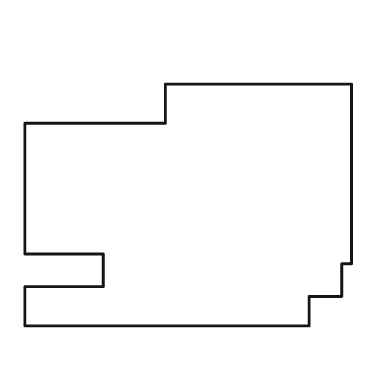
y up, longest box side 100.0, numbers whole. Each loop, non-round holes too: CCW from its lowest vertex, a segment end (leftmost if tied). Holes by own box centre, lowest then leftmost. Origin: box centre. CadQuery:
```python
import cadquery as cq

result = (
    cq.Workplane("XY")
    .moveTo(-50.0, -37.0)
    .lineTo(37.0, -37.0)
    .lineTo(37.0, -28.0)
    .lineTo(47.0, -28.0)
    .lineTo(47.0, -18.0)
    .lineTo(50.0, -18.0)
    .lineTo(50.0, 37.0)
    .lineTo(-7.0, 37.0)
    .lineTo(-7.0, 25.0)
    .lineTo(-50.0, 25.0)
    .lineTo(-50.0, -15.0)
    .lineTo(-26.0, -15.0)
    .lineTo(-26.0, -25.0)
    .lineTo(-50.0, -25.0)
    .close()
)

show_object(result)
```